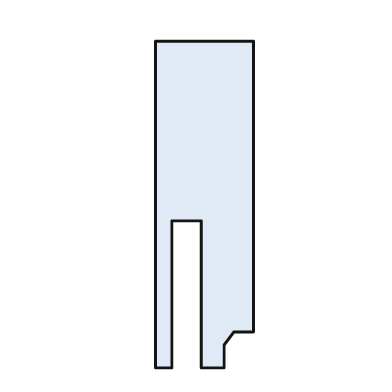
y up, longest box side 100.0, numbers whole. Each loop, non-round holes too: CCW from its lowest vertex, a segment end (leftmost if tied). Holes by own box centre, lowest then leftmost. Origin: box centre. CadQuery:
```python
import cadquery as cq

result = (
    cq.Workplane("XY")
    .moveTo(-15.0, -50.0)
    .lineTo(-10.0, -50.0)
    .lineTo(-10.0, -5.0)
    .lineTo(-1.0, -5.0)
    .lineTo(-1.0, -50.0)
    .lineTo(6.0, -50.0)
    .lineTo(6.0, -43.0)
    .lineTo(9.0, -39.0)
    .lineTo(15.0, -39.0)
    .lineTo(15.0, 50.0)
    .lineTo(-15.0, 50.0)
    .close()
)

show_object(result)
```